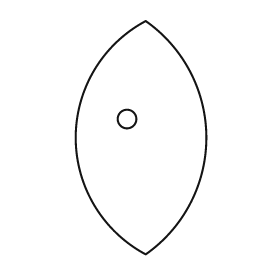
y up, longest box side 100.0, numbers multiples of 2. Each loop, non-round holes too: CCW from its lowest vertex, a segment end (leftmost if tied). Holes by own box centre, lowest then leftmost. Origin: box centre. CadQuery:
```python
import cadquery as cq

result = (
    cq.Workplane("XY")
    .moveTo(2.0, -50.0)
    .threePointArc((28.0, 0.0), (2.0, 50.0))
    .threePointArc((-28.0, 0.0), (2.0, -50.0))
    .close()
    .moveTo(-6.0, 8.0)
    .circle(4.0)
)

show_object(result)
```